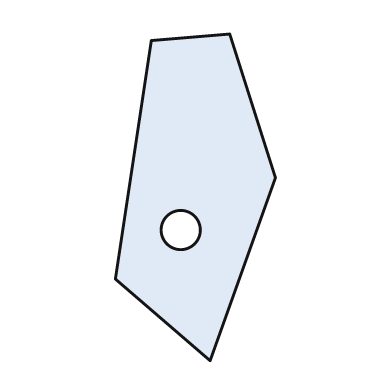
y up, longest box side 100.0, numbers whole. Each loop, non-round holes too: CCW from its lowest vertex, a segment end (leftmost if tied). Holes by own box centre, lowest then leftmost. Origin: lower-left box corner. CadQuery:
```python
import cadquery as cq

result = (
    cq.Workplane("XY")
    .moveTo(29.0, 0.0)
    .lineTo(49.0, 56.0)
    .lineTo(35.0, 100.0)
    .lineTo(11.0, 98.0)
    .lineTo(0.0, 25.0)
    .close()
    .moveTo(20.0, 40.0)
    .circle(6.0)
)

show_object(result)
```